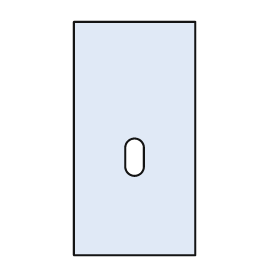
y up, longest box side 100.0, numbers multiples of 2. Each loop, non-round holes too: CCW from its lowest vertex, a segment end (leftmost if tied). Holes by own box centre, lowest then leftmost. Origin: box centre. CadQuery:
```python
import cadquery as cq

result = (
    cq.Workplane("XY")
    .moveTo(-26.0, -50.0)
    .lineTo(26.0, -50.0)
    .lineTo(26.0, 50.0)
    .lineTo(-26.0, 50.0)
    .close()
    .moveTo(-4.0, -12.0)
    .threePointArc((0.0, -16.0), (4.0, -12.0))
    .lineTo(4.0, -4.0)
    .threePointArc((0.0, 0.0), (-4.0, -4.0))
    .close()
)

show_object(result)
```